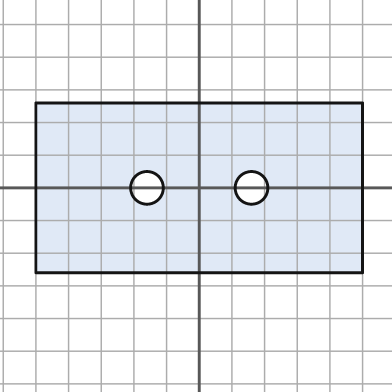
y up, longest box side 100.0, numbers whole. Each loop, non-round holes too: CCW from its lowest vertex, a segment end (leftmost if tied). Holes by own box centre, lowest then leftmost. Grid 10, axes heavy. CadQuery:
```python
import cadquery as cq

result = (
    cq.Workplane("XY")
    .moveTo(-50.0, -26.0)
    .lineTo(50.0, -26.0)
    .lineTo(50.0, 26.0)
    .lineTo(-50.0, 26.0)
    .close()
    .moveTo(-16.0, 0.0)
    .circle(5.0)
    .moveTo(16.0, 0.0)
    .circle(5.0)
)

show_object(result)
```